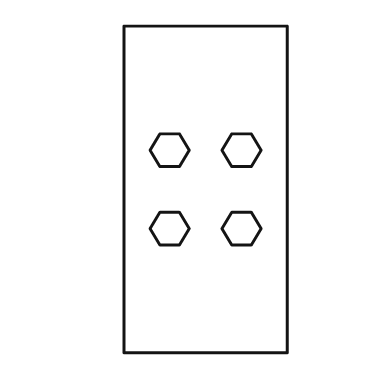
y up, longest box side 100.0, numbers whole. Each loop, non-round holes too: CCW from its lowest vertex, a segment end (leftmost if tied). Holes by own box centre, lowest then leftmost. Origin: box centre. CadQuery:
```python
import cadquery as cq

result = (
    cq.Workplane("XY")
    .moveTo(-25.0, -50.0)
    .lineTo(25.0, -50.0)
    .lineTo(25.0, 50.0)
    .lineTo(-25.0, 50.0)
    .close()
    .moveTo(-14.0, -17.0)
    .lineTo(-8.0, -17.0)
    .lineTo(-5.0, -12.0)
    .lineTo(-8.0, -7.0)
    .lineTo(-14.0, -7.0)
    .lineTo(-17.0, -12.0)
    .close()
    .moveTo(8.0, -17.0)
    .lineTo(14.0, -17.0)
    .lineTo(17.0, -12.0)
    .lineTo(14.0, -7.0)
    .lineTo(8.0, -7.0)
    .lineTo(5.0, -12.0)
    .close()
    .moveTo(-14.0, 7.0)
    .lineTo(-8.0, 7.0)
    .lineTo(-5.0, 12.0)
    .lineTo(-8.0, 17.0)
    .lineTo(-14.0, 17.0)
    .lineTo(-17.0, 12.0)
    .close()
    .moveTo(8.0, 7.0)
    .lineTo(14.0, 7.0)
    .lineTo(17.0, 12.0)
    .lineTo(14.0, 17.0)
    .lineTo(8.0, 17.0)
    .lineTo(5.0, 12.0)
    .close()
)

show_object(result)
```